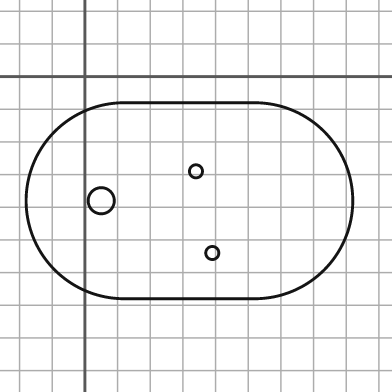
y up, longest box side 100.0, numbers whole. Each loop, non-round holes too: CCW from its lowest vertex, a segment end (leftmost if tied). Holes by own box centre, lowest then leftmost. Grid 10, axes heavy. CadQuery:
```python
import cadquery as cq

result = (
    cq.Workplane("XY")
    .moveTo(12.0, -68.0)
    .lineTo(52.0, -68.0)
    .threePointArc((82.0, -38.0), (52.0, -8.0))
    .lineTo(12.0, -8.0)
    .threePointArc((-18.0, -38.0), (12.0, -68.0))
    .close()
    .moveTo(39.0, -54.0)
    .circle(2.0)
    .moveTo(5.0, -38.0)
    .circle(4.0)
    .moveTo(34.0, -29.0)
    .circle(2.0)
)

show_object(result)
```